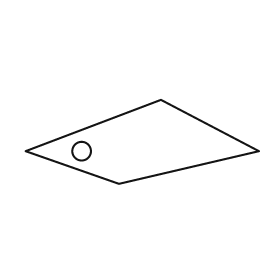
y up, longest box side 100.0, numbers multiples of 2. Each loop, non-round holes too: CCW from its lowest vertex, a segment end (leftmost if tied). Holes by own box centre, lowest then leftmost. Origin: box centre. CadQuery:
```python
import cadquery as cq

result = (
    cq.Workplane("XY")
    .moveTo(-10.0, -18.0)
    .lineTo(50.0, -4.0)
    .lineTo(8.0, 18.0)
    .lineTo(-50.0, -4.0)
    .close()
    .moveTo(-26.0, -4.0)
    .circle(4.0)
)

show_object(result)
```